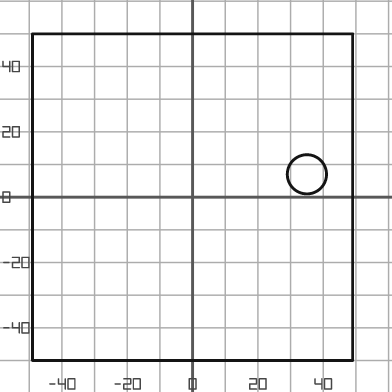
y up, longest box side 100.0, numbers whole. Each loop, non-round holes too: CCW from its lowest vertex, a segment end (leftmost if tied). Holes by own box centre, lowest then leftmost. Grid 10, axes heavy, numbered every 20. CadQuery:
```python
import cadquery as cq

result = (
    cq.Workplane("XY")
    .moveTo(-49.0, -50.0)
    .lineTo(49.0, -50.0)
    .lineTo(49.0, 50.0)
    .lineTo(-49.0, 50.0)
    .close()
    .moveTo(35.0, 7.0)
    .circle(6.0)
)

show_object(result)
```